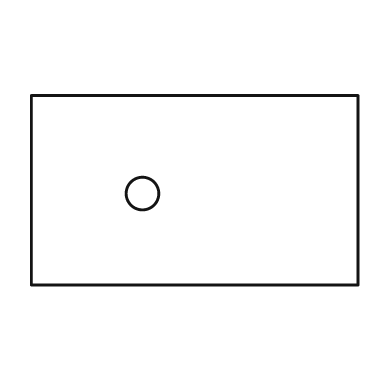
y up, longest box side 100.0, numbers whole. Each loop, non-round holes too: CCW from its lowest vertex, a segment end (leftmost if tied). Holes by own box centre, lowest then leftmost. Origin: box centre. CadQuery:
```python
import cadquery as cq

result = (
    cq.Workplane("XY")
    .moveTo(-50.0, -29.0)
    .lineTo(50.0, -29.0)
    .lineTo(50.0, 29.0)
    .lineTo(-50.0, 29.0)
    .close()
    .moveTo(-16.0, -1.0)
    .circle(5.0)
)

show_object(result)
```